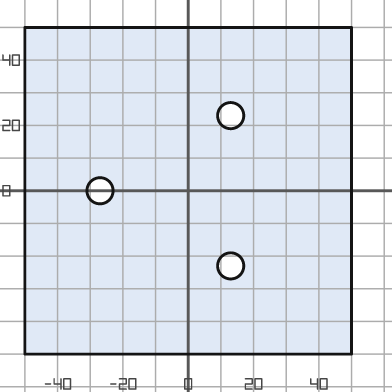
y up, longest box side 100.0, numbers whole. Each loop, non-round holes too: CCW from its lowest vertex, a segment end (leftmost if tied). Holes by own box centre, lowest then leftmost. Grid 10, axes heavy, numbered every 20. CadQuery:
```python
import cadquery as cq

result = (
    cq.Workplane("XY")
    .moveTo(-50.0, -50.0)
    .lineTo(50.0, -50.0)
    .lineTo(50.0, 50.0)
    .lineTo(-50.0, 50.0)
    .close()
    .moveTo(13.0, -23.0)
    .circle(4.0)
    .moveTo(-27.0, 0.0)
    .circle(4.0)
    .moveTo(13.0, 23.0)
    .circle(4.0)
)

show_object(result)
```